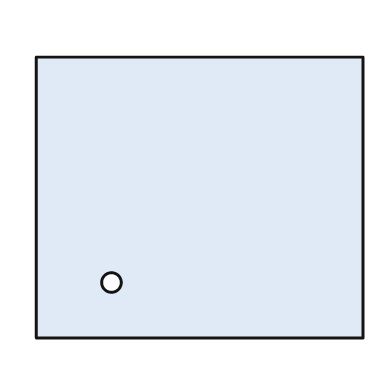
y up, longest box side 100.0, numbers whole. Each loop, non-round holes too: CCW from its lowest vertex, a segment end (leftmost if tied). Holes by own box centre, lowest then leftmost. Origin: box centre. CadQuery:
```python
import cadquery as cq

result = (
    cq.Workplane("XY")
    .moveTo(-50.0, -43.0)
    .lineTo(50.0, -43.0)
    .lineTo(50.0, 43.0)
    .lineTo(-50.0, 43.0)
    .close()
    .moveTo(-27.0, -26.0)
    .circle(3.0)
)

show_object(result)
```